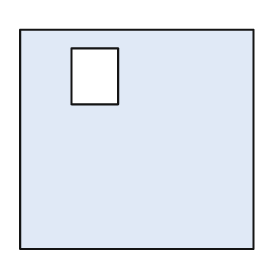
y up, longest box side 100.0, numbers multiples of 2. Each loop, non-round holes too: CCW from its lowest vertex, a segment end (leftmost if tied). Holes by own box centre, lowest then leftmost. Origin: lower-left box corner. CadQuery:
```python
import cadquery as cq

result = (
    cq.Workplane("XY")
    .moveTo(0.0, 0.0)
    .lineTo(100.0, 0.0)
    .lineTo(100.0, 94.0)
    .lineTo(0.0, 94.0)
    .close()
    .moveTo(22.0, 62.0)
    .lineTo(42.0, 62.0)
    .lineTo(42.0, 86.0)
    .lineTo(22.0, 86.0)
    .close()
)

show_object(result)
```